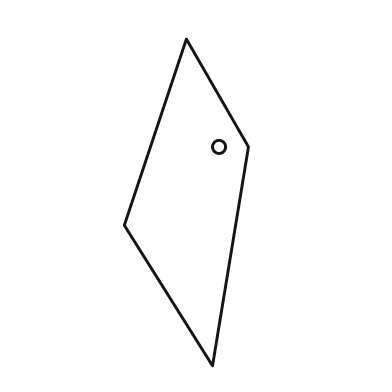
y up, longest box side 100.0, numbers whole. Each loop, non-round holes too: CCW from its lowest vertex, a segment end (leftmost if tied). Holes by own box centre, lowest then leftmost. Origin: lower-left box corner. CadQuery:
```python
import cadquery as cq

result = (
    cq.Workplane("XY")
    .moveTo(27.0, 0.0)
    .lineTo(38.0, 67.0)
    .lineTo(19.0, 100.0)
    .lineTo(0.0, 43.0)
    .close()
    .moveTo(29.0, 67.0)
    .circle(2.0)
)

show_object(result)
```